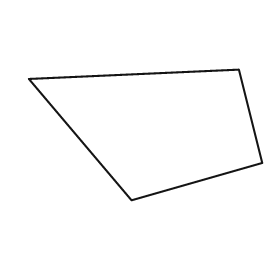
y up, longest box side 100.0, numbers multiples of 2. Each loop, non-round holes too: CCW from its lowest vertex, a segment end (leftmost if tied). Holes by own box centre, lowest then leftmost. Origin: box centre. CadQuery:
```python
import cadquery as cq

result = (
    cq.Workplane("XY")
    .moveTo(-6.0, -28.0)
    .lineTo(50.0, -12.0)
    .lineTo(40.0, 28.0)
    .lineTo(-50.0, 24.0)
    .close()
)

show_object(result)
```